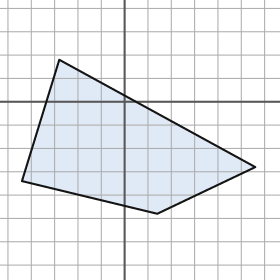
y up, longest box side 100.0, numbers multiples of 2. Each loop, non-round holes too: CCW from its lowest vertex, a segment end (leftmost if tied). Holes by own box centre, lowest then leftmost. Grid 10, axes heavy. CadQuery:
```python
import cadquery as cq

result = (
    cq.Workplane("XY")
    .moveTo(14.0, -48.0)
    .lineTo(56.0, -28.0)
    .lineTo(-28.0, 18.0)
    .lineTo(-44.0, -34.0)
    .close()
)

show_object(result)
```